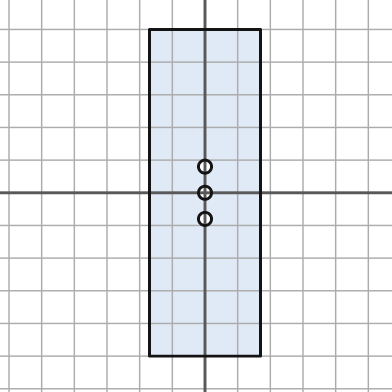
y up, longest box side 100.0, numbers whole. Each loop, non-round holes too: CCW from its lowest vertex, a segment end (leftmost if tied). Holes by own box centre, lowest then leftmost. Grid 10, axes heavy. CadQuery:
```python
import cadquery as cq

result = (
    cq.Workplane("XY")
    .moveTo(-17.0, -50.0)
    .lineTo(17.0, -50.0)
    .lineTo(17.0, 50.0)
    .lineTo(-17.0, 50.0)
    .close()
    .moveTo(0.0, -8.0)
    .circle(2.0)
    .moveTo(0.0, 0.0)
    .circle(2.0)
    .moveTo(0.0, 8.0)
    .circle(2.0)
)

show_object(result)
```